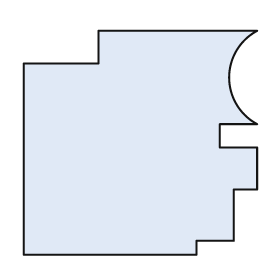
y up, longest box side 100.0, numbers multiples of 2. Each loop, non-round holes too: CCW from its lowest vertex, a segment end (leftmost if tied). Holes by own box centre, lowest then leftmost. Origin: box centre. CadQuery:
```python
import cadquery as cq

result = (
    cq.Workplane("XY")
    .moveTo(-50.0, -48.0)
    .lineTo(24.0, -48.0)
    .lineTo(24.0, -42.0)
    .lineTo(40.0, -42.0)
    .lineTo(40.0, -20.0)
    .lineTo(50.0, -20.0)
    .lineTo(50.0, -2.0)
    .lineTo(34.0, -2.0)
    .lineTo(34.0, 8.0)
    .lineTo(50.0, 8.0)
    .threePointArc((38.0, 28.0), (50.0, 48.0))
    .lineTo(-18.0, 48.0)
    .lineTo(-18.0, 34.0)
    .lineTo(-50.0, 34.0)
    .close()
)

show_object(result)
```